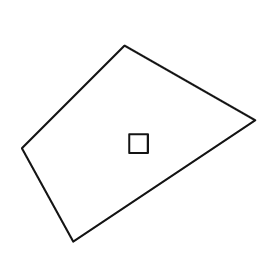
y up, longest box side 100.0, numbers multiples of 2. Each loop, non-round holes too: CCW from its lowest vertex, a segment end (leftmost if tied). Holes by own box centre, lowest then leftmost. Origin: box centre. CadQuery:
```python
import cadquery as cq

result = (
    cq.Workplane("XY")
    .moveTo(-28.0, -42.0)
    .lineTo(50.0, 10.0)
    .lineTo(-6.0, 42.0)
    .lineTo(-50.0, -2.0)
    .close()
    .moveTo(-4.0, -4.0)
    .lineTo(4.0, -4.0)
    .lineTo(4.0, 4.0)
    .lineTo(-4.0, 4.0)
    .close()
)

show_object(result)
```